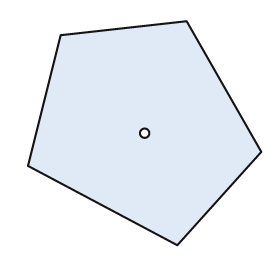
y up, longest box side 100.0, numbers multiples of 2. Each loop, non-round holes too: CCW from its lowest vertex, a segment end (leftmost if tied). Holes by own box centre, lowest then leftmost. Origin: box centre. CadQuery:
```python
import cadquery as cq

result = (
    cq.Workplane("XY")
    .moveTo(14.0, -48.0)
    .lineTo(50.0, -8.0)
    .lineTo(18.0, 48.0)
    .lineTo(-36.0, 42.0)
    .lineTo(-50.0, -14.0)
    .close()
    .moveTo(0.0, 0.0)
    .circle(2.0)
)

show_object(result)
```